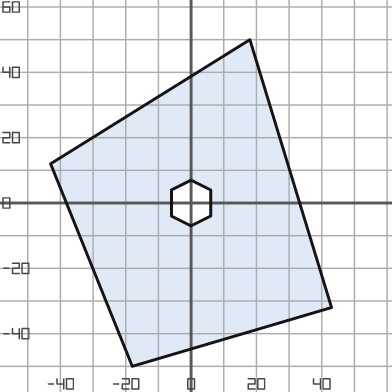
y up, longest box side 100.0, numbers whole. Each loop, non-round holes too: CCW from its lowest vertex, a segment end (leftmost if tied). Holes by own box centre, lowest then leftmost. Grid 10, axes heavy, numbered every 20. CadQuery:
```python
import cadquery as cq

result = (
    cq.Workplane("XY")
    .moveTo(-18.0, -50.0)
    .lineTo(43.0, -32.0)
    .lineTo(18.0, 50.0)
    .lineTo(-43.0, 12.0)
    .close()
    .moveTo(0.0, -7.0)
    .lineTo(6.0, -4.0)
    .lineTo(6.0, 4.0)
    .lineTo(0.0, 7.0)
    .lineTo(-6.0, 4.0)
    .lineTo(-6.0, -4.0)
    .close()
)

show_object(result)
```